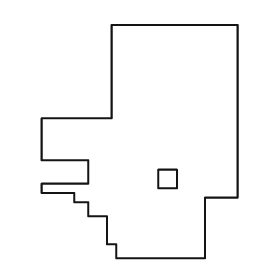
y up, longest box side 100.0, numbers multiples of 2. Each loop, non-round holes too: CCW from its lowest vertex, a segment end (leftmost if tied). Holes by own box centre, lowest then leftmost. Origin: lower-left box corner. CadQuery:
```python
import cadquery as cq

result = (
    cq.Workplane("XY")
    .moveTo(32.0, 0.0)
    .lineTo(70.0, 0.0)
    .lineTo(70.0, 26.0)
    .lineTo(84.0, 26.0)
    .lineTo(84.0, 100.0)
    .lineTo(30.0, 100.0)
    .lineTo(30.0, 60.0)
    .lineTo(0.0, 60.0)
    .lineTo(0.0, 42.0)
    .lineTo(20.0, 42.0)
    .lineTo(20.0, 32.0)
    .lineTo(0.0, 32.0)
    .lineTo(0.0, 28.0)
    .lineTo(14.0, 28.0)
    .lineTo(14.0, 24.0)
    .lineTo(20.0, 24.0)
    .lineTo(20.0, 18.0)
    .lineTo(28.0, 18.0)
    .lineTo(28.0, 6.0)
    .lineTo(32.0, 6.0)
    .close()
    .moveTo(50.0, 30.0)
    .lineTo(58.0, 30.0)
    .lineTo(58.0, 38.0)
    .lineTo(50.0, 38.0)
    .close()
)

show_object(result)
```